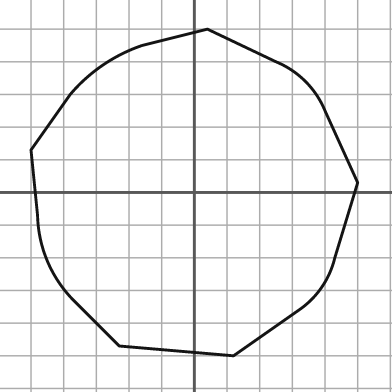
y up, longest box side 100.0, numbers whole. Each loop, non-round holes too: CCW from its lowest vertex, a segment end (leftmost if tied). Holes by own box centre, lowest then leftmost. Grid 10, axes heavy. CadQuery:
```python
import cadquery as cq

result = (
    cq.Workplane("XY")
    .moveTo(12.0, -50.0)
    .lineTo(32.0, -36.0)
    .threePointArc((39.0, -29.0), (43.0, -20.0))
    .lineTo(50.0, 3.0)
    .lineTo(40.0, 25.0)
    .threePointArc((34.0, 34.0), (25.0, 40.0))
    .lineTo(4.0, 50.0)
    .lineTo(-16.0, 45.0)
    .threePointArc((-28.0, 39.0), (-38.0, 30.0))
    .lineTo(-50.0, 13.0)
    .lineTo(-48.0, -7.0)
    .threePointArc((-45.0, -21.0), (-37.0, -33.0))
    .lineTo(-23.0, -47.0)
    .close()
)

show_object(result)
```